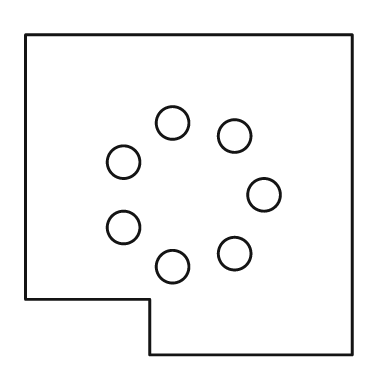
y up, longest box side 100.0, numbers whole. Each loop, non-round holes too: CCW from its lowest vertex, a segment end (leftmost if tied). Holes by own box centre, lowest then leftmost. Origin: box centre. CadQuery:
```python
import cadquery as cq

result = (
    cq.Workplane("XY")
    .moveTo(-12.0, -49.0)
    .lineTo(50.0, -49.0)
    .lineTo(50.0, 49.0)
    .lineTo(-50.0, 49.0)
    .lineTo(-50.0, -32.0)
    .lineTo(-12.0, -32.0)
    .close()
    .moveTo(-5.0, -22.0)
    .circle(5.0)
    .moveTo(14.0, -18.0)
    .circle(5.0)
    .moveTo(-20.0, -10.0)
    .circle(5.0)
    .moveTo(23.0, 0.0)
    .circle(5.0)
    .moveTo(-20.0, 10.0)
    .circle(5.0)
    .moveTo(14.0, 18.0)
    .circle(5.0)
    .moveTo(-5.0, 22.0)
    .circle(5.0)
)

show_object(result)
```